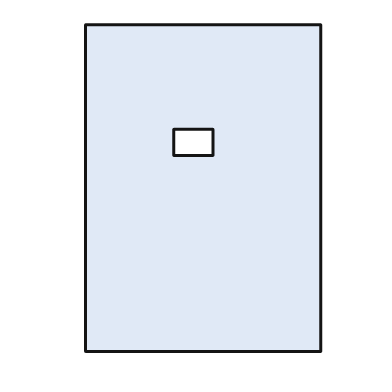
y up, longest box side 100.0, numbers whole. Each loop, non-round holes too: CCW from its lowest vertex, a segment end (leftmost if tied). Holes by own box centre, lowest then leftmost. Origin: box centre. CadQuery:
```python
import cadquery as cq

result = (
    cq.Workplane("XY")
    .moveTo(-36.0, -50.0)
    .lineTo(36.0, -50.0)
    .lineTo(36.0, 50.0)
    .lineTo(-36.0, 50.0)
    .close()
    .moveTo(-9.0, 10.0)
    .lineTo(3.0, 10.0)
    .lineTo(3.0, 18.0)
    .lineTo(-9.0, 18.0)
    .close()
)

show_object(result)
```